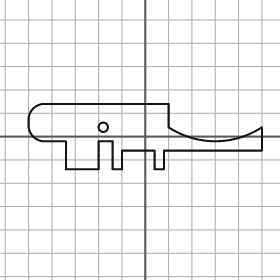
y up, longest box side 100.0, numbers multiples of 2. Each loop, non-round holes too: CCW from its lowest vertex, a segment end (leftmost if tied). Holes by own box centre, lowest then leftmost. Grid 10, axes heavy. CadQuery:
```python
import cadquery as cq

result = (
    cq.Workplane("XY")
    .moveTo(-34.0, -14.0)
    .lineTo(-20.0, -14.0)
    .lineTo(-20.0, -2.0)
    .lineTo(-14.0, -2.0)
    .lineTo(-14.0, -14.0)
    .lineTo(-10.0, -14.0)
    .lineTo(-10.0, -6.0)
    .lineTo(4.0, -6.0)
    .lineTo(4.0, -14.0)
    .lineTo(8.0, -14.0)
    .lineTo(8.0, -6.0)
    .lineTo(50.0, -6.0)
    .lineTo(50.0, 4.0)
    .threePointArc((30.0, -2.0), (10.0, 4.0))
    .lineTo(10.0, 14.0)
    .lineTo(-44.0, 14.0)
    .threePointArc((-48.0, 12.0), (-50.0, 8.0))
    .lineTo(-50.0, 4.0)
    .threePointArc((-48.0, 0.0), (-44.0, -2.0))
    .lineTo(-34.0, -2.0)
    .close()
    .moveTo(-18.0, 4.0)
    .circle(2.0)
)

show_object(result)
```